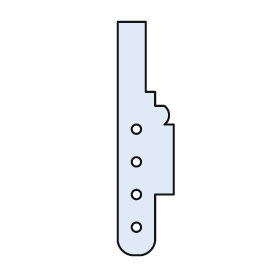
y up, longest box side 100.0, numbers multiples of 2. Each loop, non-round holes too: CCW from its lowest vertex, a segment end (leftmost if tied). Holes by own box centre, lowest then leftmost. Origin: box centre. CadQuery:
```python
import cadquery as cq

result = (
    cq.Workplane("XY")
    .moveTo(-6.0, -50.0)
    .lineTo(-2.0, -50.0)
    .threePointArc((2.0, -48.0), (4.0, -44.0))
    .lineTo(4.0, -24.0)
    .lineTo(12.0, -24.0)
    .lineTo(12.0, 6.0)
    .lineTo(8.0, 6.0)
    .threePointArc((10.0, 10.0), (8.0, 14.0))
    .lineTo(4.0, 14.0)
    .lineTo(4.0, 20.0)
    .lineTo(0.0, 20.0)
    .lineTo(0.0, 50.0)
    .lineTo(-12.0, 50.0)
    .lineTo(-12.0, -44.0)
    .threePointArc((-10.0, -48.0), (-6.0, -50.0))
    .close()
    .moveTo(-4.0, -38.0)
    .circle(2.0)
    .moveTo(-4.0, -24.0)
    .circle(2.0)
    .moveTo(-4.0, -10.0)
    .circle(2.0)
    .moveTo(-4.0, 4.0)
    .circle(2.0)
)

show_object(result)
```